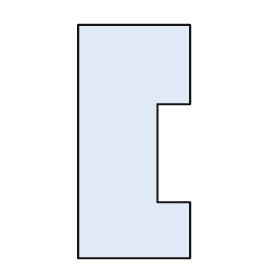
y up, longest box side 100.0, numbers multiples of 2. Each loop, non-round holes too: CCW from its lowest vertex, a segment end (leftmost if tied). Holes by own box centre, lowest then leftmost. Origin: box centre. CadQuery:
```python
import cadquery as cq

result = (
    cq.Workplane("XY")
    .moveTo(-24.0, -50.0)
    .lineTo(24.0, -50.0)
    .lineTo(24.0, -26.0)
    .lineTo(10.0, -26.0)
    .lineTo(10.0, 16.0)
    .lineTo(24.0, 16.0)
    .lineTo(24.0, 50.0)
    .lineTo(-24.0, 50.0)
    .close()
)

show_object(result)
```